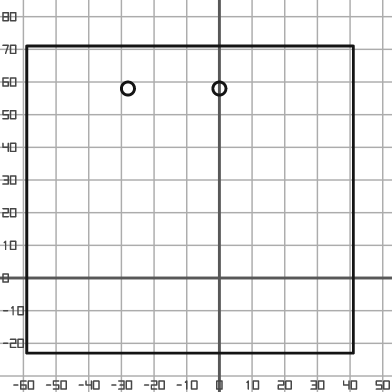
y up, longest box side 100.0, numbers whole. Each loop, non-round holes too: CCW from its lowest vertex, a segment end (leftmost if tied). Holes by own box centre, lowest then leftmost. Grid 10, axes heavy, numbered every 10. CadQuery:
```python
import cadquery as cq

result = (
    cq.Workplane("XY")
    .moveTo(-59.0, -23.0)
    .lineTo(41.0, -23.0)
    .lineTo(41.0, 71.0)
    .lineTo(-59.0, 71.0)
    .close()
    .moveTo(-28.0, 58.0)
    .circle(2.0)
    .moveTo(0.0, 58.0)
    .circle(2.0)
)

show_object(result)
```